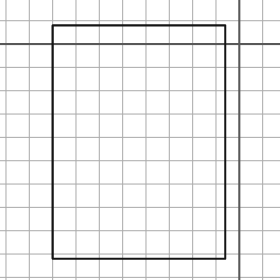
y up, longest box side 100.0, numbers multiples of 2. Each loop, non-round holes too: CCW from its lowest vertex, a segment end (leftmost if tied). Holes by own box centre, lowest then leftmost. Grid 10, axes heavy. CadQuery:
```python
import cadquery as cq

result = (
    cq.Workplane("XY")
    .moveTo(-80.0, -92.0)
    .lineTo(-6.0, -92.0)
    .lineTo(-6.0, 8.0)
    .lineTo(-80.0, 8.0)
    .close()
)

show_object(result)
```